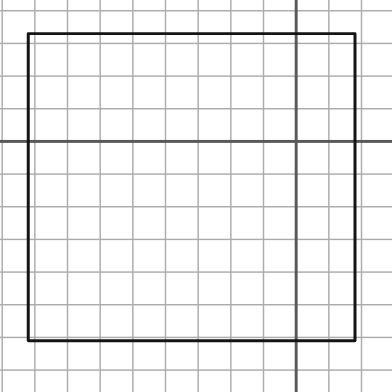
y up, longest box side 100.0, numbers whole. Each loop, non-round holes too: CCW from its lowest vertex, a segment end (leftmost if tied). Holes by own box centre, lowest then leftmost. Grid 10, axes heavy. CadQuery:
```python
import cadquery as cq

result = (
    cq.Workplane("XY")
    .moveTo(-82.0, -61.0)
    .lineTo(18.0, -61.0)
    .lineTo(18.0, 33.0)
    .lineTo(-82.0, 33.0)
    .close()
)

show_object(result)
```